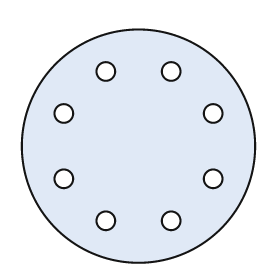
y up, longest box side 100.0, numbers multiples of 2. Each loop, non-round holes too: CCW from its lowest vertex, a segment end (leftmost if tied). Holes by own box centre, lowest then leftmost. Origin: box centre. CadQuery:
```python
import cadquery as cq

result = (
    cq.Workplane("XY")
    .moveTo(0.0, 0.0)
    .circle(50.0)
    .moveTo(-14.0, -32.0)
    .circle(4.0)
    .moveTo(14.0, -32.0)
    .circle(4.0)
    .moveTo(-32.0, -14.0)
    .circle(4.0)
    .moveTo(32.0, -14.0)
    .circle(4.0)
    .moveTo(-32.0, 14.0)
    .circle(4.0)
    .moveTo(32.0, 14.0)
    .circle(4.0)
    .moveTo(-14.0, 32.0)
    .circle(4.0)
    .moveTo(14.0, 32.0)
    .circle(4.0)
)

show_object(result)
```